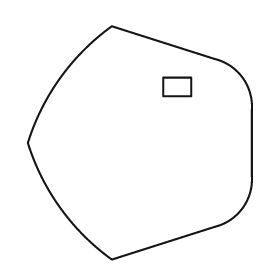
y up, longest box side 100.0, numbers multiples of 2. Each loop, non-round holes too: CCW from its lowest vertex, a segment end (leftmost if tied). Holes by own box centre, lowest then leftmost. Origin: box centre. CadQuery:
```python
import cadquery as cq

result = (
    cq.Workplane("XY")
    .moveTo(-12.0, -50.0)
    .lineTo(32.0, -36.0)
    .threePointArc((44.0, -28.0), (48.0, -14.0))
    .lineTo(48.0, 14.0)
    .threePointArc((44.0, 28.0), (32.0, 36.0))
    .lineTo(-12.0, 50.0)
    .threePointArc((-34.0, 28.0), (-48.0, 0.0))
    .threePointArc((-34.0, -28.0), (-12.0, -50.0))
    .close()
    .moveTo(10.0, 20.0)
    .lineTo(22.0, 20.0)
    .lineTo(22.0, 28.0)
    .lineTo(10.0, 28.0)
    .close()
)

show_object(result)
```